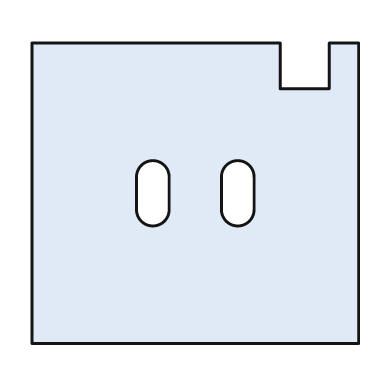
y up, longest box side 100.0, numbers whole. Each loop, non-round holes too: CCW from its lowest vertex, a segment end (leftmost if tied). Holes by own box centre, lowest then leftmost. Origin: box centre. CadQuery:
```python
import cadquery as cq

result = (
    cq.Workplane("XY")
    .moveTo(-50.0, -46.0)
    .lineTo(50.0, -46.0)
    .lineTo(50.0, 46.0)
    .lineTo(41.0, 46.0)
    .lineTo(41.0, 32.0)
    .lineTo(26.0, 32.0)
    .lineTo(26.0, 46.0)
    .lineTo(-50.0, 46.0)
    .close()
    .moveTo(-18.0, -5.0)
    .threePointArc((-13.0, -10.0), (-8.0, -5.0))
    .lineTo(-8.0, 5.0)
    .threePointArc((-13.0, 10.0), (-18.0, 5.0))
    .close()
    .moveTo(8.0, -5.0)
    .threePointArc((13.0, -10.0), (18.0, -5.0))
    .lineTo(18.0, 5.0)
    .threePointArc((13.0, 10.0), (8.0, 5.0))
    .close()
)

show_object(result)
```